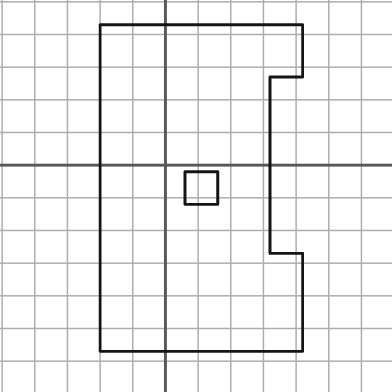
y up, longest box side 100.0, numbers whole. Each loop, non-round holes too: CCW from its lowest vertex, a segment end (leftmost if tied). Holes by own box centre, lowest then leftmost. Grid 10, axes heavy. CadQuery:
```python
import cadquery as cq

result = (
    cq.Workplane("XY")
    .moveTo(-20.0, -57.0)
    .lineTo(42.0, -57.0)
    .lineTo(42.0, -27.0)
    .lineTo(32.0, -27.0)
    .lineTo(32.0, 27.0)
    .lineTo(42.0, 27.0)
    .lineTo(42.0, 43.0)
    .lineTo(-20.0, 43.0)
    .close()
    .moveTo(6.0, -12.0)
    .lineTo(16.0, -12.0)
    .lineTo(16.0, -2.0)
    .lineTo(6.0, -2.0)
    .close()
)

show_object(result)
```